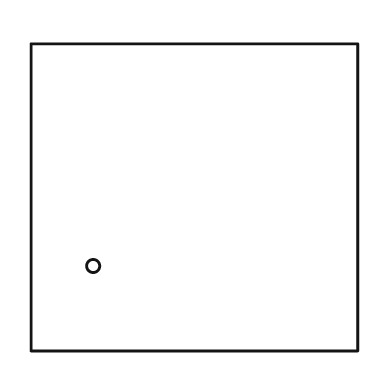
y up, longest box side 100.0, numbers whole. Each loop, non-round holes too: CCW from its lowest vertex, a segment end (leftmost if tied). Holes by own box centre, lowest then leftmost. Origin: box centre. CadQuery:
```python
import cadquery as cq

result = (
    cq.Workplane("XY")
    .moveTo(-50.0, -47.0)
    .lineTo(50.0, -47.0)
    .lineTo(50.0, 47.0)
    .lineTo(-50.0, 47.0)
    .close()
    .moveTo(-31.0, -21.0)
    .circle(2.0)
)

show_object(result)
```